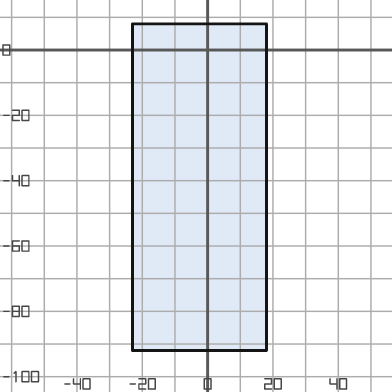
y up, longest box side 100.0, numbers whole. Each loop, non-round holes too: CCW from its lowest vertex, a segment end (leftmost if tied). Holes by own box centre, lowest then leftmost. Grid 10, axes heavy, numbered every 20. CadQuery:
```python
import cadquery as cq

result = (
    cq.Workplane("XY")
    .moveTo(-23.0, -92.0)
    .lineTo(18.0, -92.0)
    .lineTo(18.0, 8.0)
    .lineTo(-23.0, 8.0)
    .close()
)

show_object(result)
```